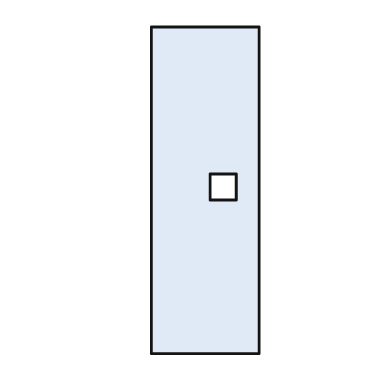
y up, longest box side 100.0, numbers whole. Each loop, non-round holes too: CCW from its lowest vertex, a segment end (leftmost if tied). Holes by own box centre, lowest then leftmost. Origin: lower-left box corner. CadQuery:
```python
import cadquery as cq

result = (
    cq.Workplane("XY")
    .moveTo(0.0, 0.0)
    .lineTo(33.0, 0.0)
    .lineTo(33.0, 100.0)
    .lineTo(0.0, 100.0)
    .close()
    .moveTo(18.0, 47.0)
    .lineTo(26.0, 47.0)
    .lineTo(26.0, 55.0)
    .lineTo(18.0, 55.0)
    .close()
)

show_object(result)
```